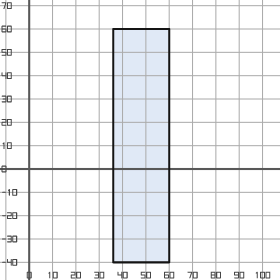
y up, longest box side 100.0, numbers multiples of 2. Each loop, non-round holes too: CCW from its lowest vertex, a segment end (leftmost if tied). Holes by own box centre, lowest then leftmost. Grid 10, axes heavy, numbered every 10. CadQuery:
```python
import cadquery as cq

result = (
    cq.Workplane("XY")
    .moveTo(36.0, -40.0)
    .lineTo(60.0, -40.0)
    .lineTo(60.0, 60.0)
    .lineTo(36.0, 60.0)
    .close()
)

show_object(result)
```